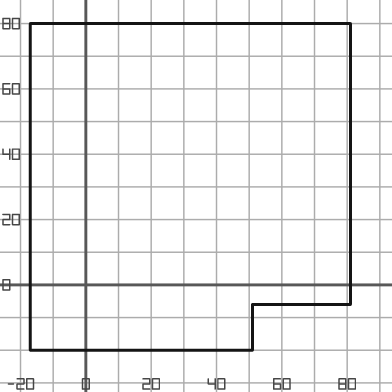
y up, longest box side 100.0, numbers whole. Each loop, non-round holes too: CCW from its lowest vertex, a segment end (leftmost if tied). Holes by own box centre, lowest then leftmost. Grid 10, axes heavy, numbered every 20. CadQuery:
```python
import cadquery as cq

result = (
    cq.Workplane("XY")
    .moveTo(-17.0, -20.0)
    .lineTo(51.0, -20.0)
    .lineTo(51.0, -6.0)
    .lineTo(81.0, -6.0)
    .lineTo(81.0, 80.0)
    .lineTo(-17.0, 80.0)
    .close()
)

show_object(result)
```